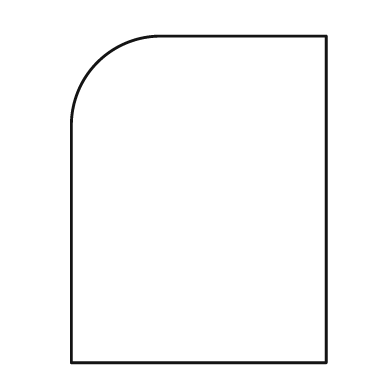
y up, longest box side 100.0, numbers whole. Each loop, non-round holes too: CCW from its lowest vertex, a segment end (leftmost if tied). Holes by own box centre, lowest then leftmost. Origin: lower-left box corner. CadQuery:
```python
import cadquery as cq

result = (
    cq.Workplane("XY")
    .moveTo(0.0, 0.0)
    .lineTo(78.0, 0.0)
    .lineTo(78.0, 100.0)
    .lineTo(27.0, 100.0)
    .threePointArc((8.0, 92.0), (0.0, 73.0))
    .close()
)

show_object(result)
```